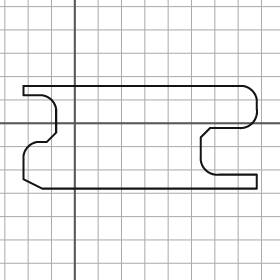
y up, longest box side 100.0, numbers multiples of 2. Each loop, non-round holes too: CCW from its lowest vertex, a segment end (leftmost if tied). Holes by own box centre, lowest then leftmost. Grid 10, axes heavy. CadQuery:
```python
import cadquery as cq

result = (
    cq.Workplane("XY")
    .moveTo(-14.0, -28.0)
    .lineTo(78.0, -28.0)
    .lineTo(78.0, -22.0)
    .lineTo(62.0, -22.0)
    .threePointArc((56.0, -20.0), (54.0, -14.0))
    .lineTo(54.0, -6.0)
    .lineTo(58.0, -2.0)
    .lineTo(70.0, -2.0)
    .threePointArc((76.0, 0.0), (78.0, 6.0))
    .lineTo(78.0, 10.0)
    .threePointArc((76.0, 14.0), (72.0, 16.0))
    .lineTo(-22.0, 16.0)
    .lineTo(-22.0, 12.0)
    .lineTo(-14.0, 12.0)
    .threePointArc((-10.0, 10.0), (-8.0, 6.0))
    .lineTo(-8.0, -4.0)
    .lineTo(-12.0, -8.0)
    .lineTo(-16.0, -8.0)
    .threePointArc((-20.0, -10.0), (-22.0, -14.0))
    .lineTo(-22.0, -24.0)
    .close()
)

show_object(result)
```